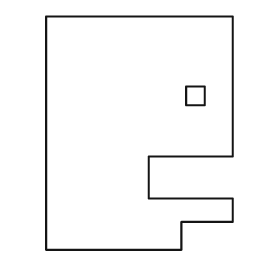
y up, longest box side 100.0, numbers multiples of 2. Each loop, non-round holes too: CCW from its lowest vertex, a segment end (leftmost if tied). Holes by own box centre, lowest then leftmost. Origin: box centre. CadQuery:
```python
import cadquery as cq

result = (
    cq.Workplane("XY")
    .moveTo(-40.0, -50.0)
    .lineTo(18.0, -50.0)
    .lineTo(18.0, -38.0)
    .lineTo(40.0, -38.0)
    .lineTo(40.0, -28.0)
    .lineTo(4.0, -28.0)
    .lineTo(4.0, -10.0)
    .lineTo(40.0, -10.0)
    .lineTo(40.0, 50.0)
    .lineTo(-40.0, 50.0)
    .close()
    .moveTo(20.0, 12.0)
    .lineTo(28.0, 12.0)
    .lineTo(28.0, 20.0)
    .lineTo(20.0, 20.0)
    .close()
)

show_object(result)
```